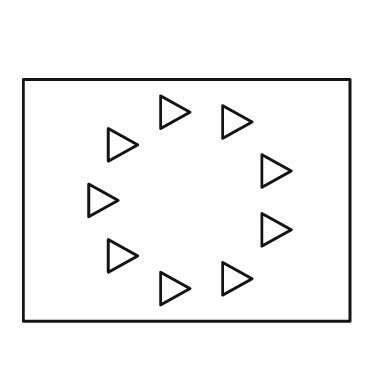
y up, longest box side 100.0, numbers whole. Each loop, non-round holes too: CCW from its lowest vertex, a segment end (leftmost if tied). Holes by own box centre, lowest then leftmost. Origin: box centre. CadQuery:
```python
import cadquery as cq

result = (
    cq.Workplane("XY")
    .moveTo(-50.0, -37.0)
    .lineTo(50.0, -37.0)
    .lineTo(50.0, 37.0)
    .lineTo(-50.0, 37.0)
    .close()
    .moveTo(-8.0, -32.0)
    .lineTo(1.0, -27.0)
    .lineTo(-8.0, -22.0)
    .close()
    .moveTo(11.0, -29.0)
    .lineTo(20.0, -24.0)
    .lineTo(11.0, -19.0)
    .close()
    .moveTo(-24.0, -22.0)
    .lineTo(-15.0, -17.0)
    .lineTo(-24.0, -12.0)
    .close()
    .moveTo(23.0, -14.0)
    .lineTo(32.0, -9.0)
    .lineTo(23.0, -4.0)
    .close()
    .moveTo(-30.0, -5.0)
    .lineTo(-21.0, 0.0)
    .lineTo(-30.0, 5.0)
    .close()
    .moveTo(23.0, 4.0)
    .lineTo(32.0, 9.0)
    .lineTo(23.0, 14.0)
    .close()
    .moveTo(-24.0, 12.0)
    .lineTo(-15.0, 17.0)
    .lineTo(-24.0, 22.0)
    .close()
    .moveTo(11.0, 19.0)
    .lineTo(20.0, 24.0)
    .lineTo(11.0, 29.0)
    .close()
    .moveTo(-8.0, 22.0)
    .lineTo(1.0, 27.0)
    .lineTo(-8.0, 32.0)
    .close()
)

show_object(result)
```